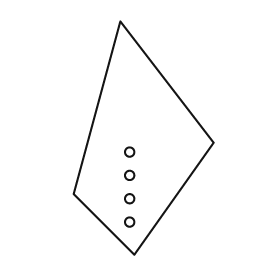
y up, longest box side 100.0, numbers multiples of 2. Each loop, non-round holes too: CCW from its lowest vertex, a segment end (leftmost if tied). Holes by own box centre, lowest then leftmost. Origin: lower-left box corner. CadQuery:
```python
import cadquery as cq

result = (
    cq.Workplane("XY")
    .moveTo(26.0, 0.0)
    .lineTo(60.0, 48.0)
    .lineTo(20.0, 100.0)
    .lineTo(0.0, 26.0)
    .close()
    .moveTo(24.0, 14.0)
    .circle(2.0)
    .moveTo(24.0, 24.0)
    .circle(2.0)
    .moveTo(24.0, 34.0)
    .circle(2.0)
    .moveTo(24.0, 44.0)
    .circle(2.0)
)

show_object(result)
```